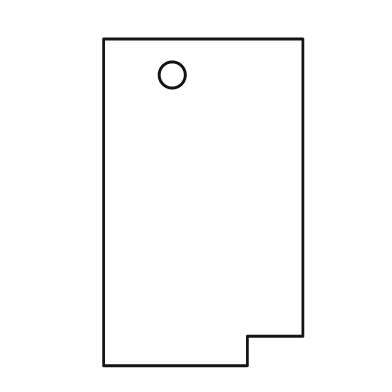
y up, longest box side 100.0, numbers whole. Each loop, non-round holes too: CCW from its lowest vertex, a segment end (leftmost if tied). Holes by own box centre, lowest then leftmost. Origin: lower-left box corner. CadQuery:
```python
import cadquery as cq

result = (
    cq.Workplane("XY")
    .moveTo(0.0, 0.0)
    .lineTo(44.0, 0.0)
    .lineTo(44.0, 9.0)
    .lineTo(61.0, 9.0)
    .lineTo(61.0, 100.0)
    .lineTo(0.0, 100.0)
    .close()
    .moveTo(21.0, 89.0)
    .circle(4.0)
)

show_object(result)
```